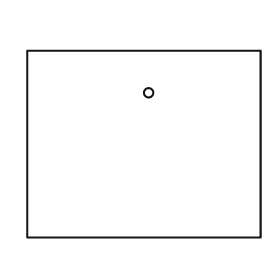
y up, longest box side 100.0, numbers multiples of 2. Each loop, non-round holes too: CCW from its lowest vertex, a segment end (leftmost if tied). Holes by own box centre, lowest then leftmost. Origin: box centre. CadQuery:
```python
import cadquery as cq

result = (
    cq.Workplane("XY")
    .moveTo(-50.0, -40.0)
    .lineTo(50.0, -40.0)
    .lineTo(50.0, 40.0)
    .lineTo(-50.0, 40.0)
    .close()
    .moveTo(2.0, 22.0)
    .circle(2.0)
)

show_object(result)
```